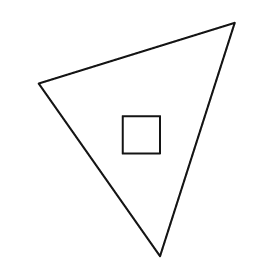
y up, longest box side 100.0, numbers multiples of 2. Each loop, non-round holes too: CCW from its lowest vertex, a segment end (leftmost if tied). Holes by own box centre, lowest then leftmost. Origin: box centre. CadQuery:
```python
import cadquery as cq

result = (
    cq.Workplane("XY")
    .moveTo(10.0, -50.0)
    .lineTo(42.0, 50.0)
    .lineTo(-42.0, 24.0)
    .close()
    .moveTo(-6.0, -6.0)
    .lineTo(10.0, -6.0)
    .lineTo(10.0, 10.0)
    .lineTo(-6.0, 10.0)
    .close()
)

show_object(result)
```